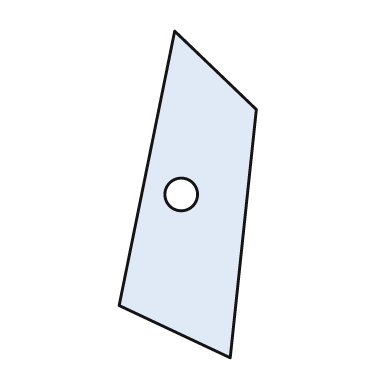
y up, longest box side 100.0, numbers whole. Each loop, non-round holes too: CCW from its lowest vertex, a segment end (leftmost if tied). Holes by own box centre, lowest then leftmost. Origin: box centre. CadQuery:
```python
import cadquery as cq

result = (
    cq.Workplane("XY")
    .moveTo(13.0, -50.0)
    .lineTo(21.0, 26.0)
    .lineTo(-4.0, 50.0)
    .lineTo(-21.0, -34.0)
    .close()
    .moveTo(-2.0, 0.0)
    .circle(5.0)
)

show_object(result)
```